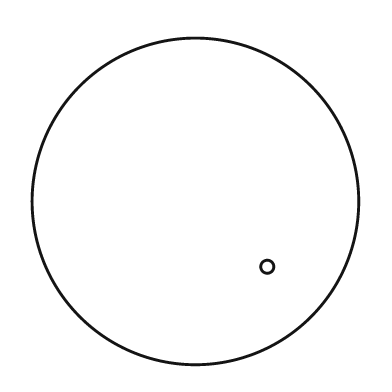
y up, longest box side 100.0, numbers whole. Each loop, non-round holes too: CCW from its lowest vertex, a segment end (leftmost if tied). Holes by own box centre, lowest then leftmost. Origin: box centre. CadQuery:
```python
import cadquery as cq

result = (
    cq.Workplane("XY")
    .moveTo(0.0, 0.0)
    .circle(50.0)
    .moveTo(22.0, -20.0)
    .circle(2.0)
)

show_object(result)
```